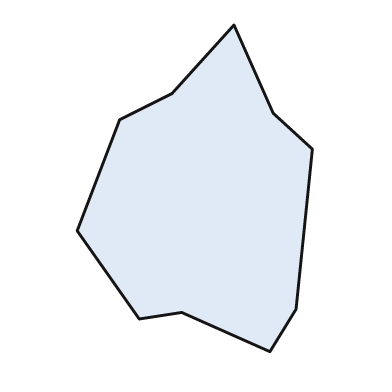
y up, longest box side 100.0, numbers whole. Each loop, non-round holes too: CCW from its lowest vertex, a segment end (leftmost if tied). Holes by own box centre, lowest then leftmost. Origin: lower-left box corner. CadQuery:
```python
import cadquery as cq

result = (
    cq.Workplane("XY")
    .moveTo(59.0, 0.0)
    .lineTo(67.0, 13.0)
    .lineTo(72.0, 62.0)
    .lineTo(60.0, 73.0)
    .lineTo(48.0, 100.0)
    .lineTo(29.0, 79.0)
    .lineTo(13.0, 71.0)
    .lineTo(0.0, 37.0)
    .lineTo(19.0, 10.0)
    .lineTo(32.0, 12.0)
    .close()
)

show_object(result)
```